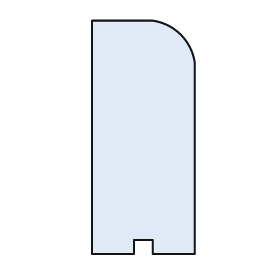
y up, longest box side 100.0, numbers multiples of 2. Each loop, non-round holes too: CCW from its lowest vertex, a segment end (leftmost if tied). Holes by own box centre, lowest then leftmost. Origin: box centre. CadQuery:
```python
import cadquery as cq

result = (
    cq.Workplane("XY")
    .moveTo(-22.0, -50.0)
    .lineTo(-4.0, -50.0)
    .lineTo(-4.0, -44.0)
    .lineTo(4.0, -44.0)
    .lineTo(4.0, -50.0)
    .lineTo(22.0, -50.0)
    .lineTo(22.0, 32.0)
    .threePointArc((16.0, 44.0), (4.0, 50.0))
    .lineTo(-22.0, 50.0)
    .close()
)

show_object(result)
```